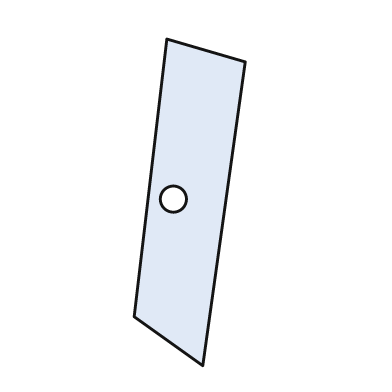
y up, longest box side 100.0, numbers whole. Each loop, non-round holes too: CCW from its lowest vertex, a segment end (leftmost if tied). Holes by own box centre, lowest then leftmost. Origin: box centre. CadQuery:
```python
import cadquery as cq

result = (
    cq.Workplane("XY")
    .moveTo(4.0, -50.0)
    .lineTo(17.0, 43.0)
    .lineTo(-7.0, 50.0)
    .lineTo(-17.0, -35.0)
    .close()
    .moveTo(-5.0, 1.0)
    .circle(4.0)
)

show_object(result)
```